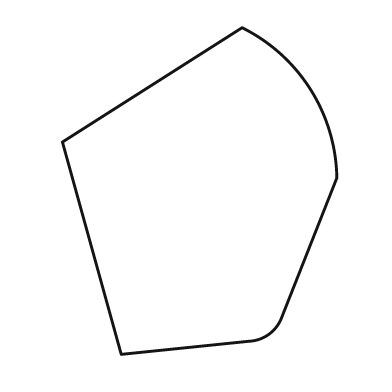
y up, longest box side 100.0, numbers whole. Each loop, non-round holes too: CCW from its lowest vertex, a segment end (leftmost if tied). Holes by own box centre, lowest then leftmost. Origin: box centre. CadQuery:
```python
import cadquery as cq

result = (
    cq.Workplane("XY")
    .moveTo(-24.0, -50.0)
    .lineTo(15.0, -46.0)
    .threePointArc((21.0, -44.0), (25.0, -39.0))
    .lineTo(42.0, 4.0)
    .threePointArc((34.0, 31.0), (13.0, 50.0))
    .lineTo(-42.0, 15.0)
    .close()
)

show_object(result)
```